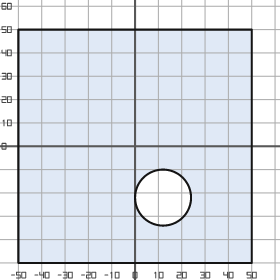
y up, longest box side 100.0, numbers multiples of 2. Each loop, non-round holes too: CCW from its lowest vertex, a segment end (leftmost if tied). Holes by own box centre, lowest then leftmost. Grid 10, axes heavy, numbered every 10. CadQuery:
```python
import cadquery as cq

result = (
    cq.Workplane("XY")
    .moveTo(-50.0, -50.0)
    .lineTo(50.0, -50.0)
    .lineTo(50.0, 50.0)
    .lineTo(-50.0, 50.0)
    .close()
    .moveTo(12.0, -22.0)
    .circle(12.0)
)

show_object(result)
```